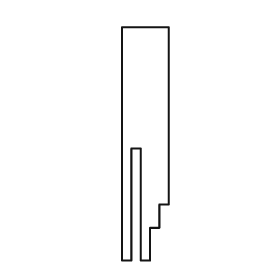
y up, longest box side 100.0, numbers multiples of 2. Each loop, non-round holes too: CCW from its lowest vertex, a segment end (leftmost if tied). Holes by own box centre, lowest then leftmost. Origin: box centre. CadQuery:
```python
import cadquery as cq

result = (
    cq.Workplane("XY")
    .moveTo(-10.0, -50.0)
    .lineTo(-6.0, -50.0)
    .lineTo(-6.0, -2.0)
    .lineTo(-2.0, -2.0)
    .lineTo(-2.0, -50.0)
    .lineTo(2.0, -50.0)
    .lineTo(2.0, -36.0)
    .lineTo(6.0, -36.0)
    .lineTo(6.0, -26.0)
    .lineTo(10.0, -26.0)
    .lineTo(10.0, 50.0)
    .lineTo(-10.0, 50.0)
    .close()
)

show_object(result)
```